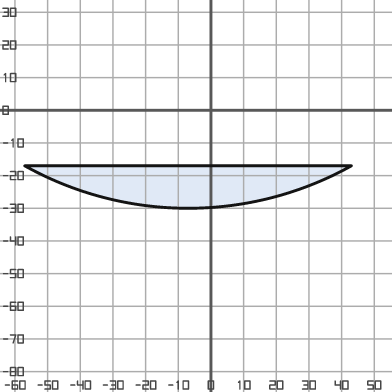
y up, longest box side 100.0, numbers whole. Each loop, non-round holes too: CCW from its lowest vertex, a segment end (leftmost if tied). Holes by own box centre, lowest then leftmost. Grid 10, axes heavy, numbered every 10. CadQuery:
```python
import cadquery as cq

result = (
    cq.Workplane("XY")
    .moveTo(-57.0, -17.0)
    .threePointArc((-7.0, -30.0), (43.0, -17.0))
    .close()
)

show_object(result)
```